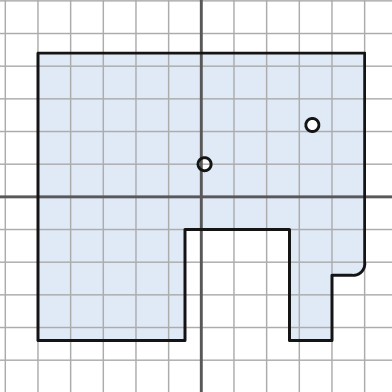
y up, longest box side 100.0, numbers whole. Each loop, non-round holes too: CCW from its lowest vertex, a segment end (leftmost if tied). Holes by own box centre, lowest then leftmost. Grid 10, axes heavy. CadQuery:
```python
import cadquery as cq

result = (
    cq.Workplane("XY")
    .moveTo(-50.0, -44.0)
    .lineTo(-5.0, -44.0)
    .lineTo(-5.0, -10.0)
    .lineTo(27.0, -10.0)
    .lineTo(27.0, -44.0)
    .lineTo(40.0, -44.0)
    .lineTo(40.0, -24.0)
    .lineTo(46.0, -24.0)
    .threePointArc((49.0, -23.0), (50.0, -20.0))
    .lineTo(50.0, 44.0)
    .lineTo(-50.0, 44.0)
    .close()
    .moveTo(1.0, 10.0)
    .circle(2.0)
    .moveTo(34.0, 22.0)
    .circle(2.0)
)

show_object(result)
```